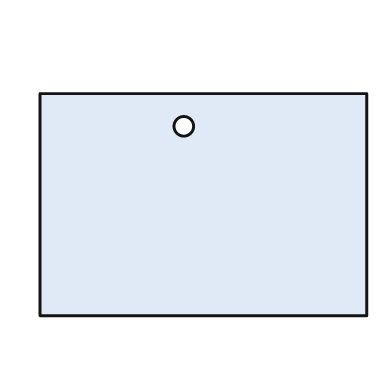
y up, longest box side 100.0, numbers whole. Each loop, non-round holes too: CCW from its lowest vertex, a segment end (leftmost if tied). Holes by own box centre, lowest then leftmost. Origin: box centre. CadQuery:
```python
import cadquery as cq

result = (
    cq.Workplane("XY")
    .moveTo(-50.0, -34.0)
    .lineTo(50.0, -34.0)
    .lineTo(50.0, 34.0)
    .lineTo(-50.0, 34.0)
    .close()
    .moveTo(-6.0, 24.0)
    .circle(3.0)
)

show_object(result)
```